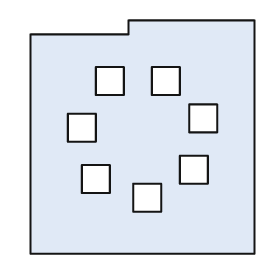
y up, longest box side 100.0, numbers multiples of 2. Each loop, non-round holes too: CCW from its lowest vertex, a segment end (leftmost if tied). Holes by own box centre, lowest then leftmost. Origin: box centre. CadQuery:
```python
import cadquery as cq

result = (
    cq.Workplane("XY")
    .moveTo(-48.0, -50.0)
    .lineTo(48.0, -50.0)
    .lineTo(48.0, 50.0)
    .lineTo(-6.0, 50.0)
    .lineTo(-6.0, 44.0)
    .lineTo(-48.0, 44.0)
    .close()
    .moveTo(-4.0, -32.0)
    .lineTo(8.0, -32.0)
    .lineTo(8.0, -20.0)
    .lineTo(-4.0, -20.0)
    .close()
    .moveTo(-26.0, -24.0)
    .lineTo(-14.0, -24.0)
    .lineTo(-14.0, -12.0)
    .lineTo(-26.0, -12.0)
    .close()
    .moveTo(16.0, -20.0)
    .lineTo(28.0, -20.0)
    .lineTo(28.0, -8.0)
    .lineTo(16.0, -8.0)
    .close()
    .moveTo(-32.0, -2.0)
    .lineTo(-20.0, -2.0)
    .lineTo(-20.0, 10.0)
    .lineTo(-32.0, 10.0)
    .close()
    .moveTo(20.0, 2.0)
    .lineTo(32.0, 2.0)
    .lineTo(32.0, 14.0)
    .lineTo(20.0, 14.0)
    .close()
    .moveTo(-20.0, 18.0)
    .lineTo(-8.0, 18.0)
    .lineTo(-8.0, 30.0)
    .lineTo(-20.0, 30.0)
    .close()
    .moveTo(4.0, 18.0)
    .lineTo(16.0, 18.0)
    .lineTo(16.0, 30.0)
    .lineTo(4.0, 30.0)
    .close()
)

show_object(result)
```